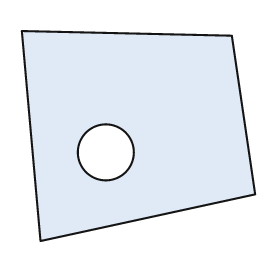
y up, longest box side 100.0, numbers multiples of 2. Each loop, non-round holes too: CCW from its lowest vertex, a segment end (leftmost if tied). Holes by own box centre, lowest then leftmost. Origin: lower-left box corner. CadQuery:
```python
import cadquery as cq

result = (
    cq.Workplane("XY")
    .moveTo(8.0, 0.0)
    .lineTo(100.0, 20.0)
    .lineTo(90.0, 88.0)
    .lineTo(0.0, 90.0)
    .close()
    .moveTo(36.0, 38.0)
    .circle(12.0)
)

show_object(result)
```